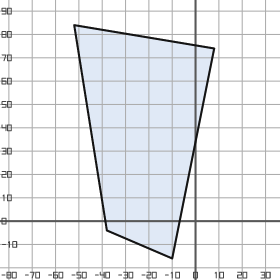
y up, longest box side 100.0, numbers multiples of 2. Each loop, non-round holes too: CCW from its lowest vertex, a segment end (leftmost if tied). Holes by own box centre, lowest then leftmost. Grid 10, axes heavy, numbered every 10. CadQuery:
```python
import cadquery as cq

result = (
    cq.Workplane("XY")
    .moveTo(-10.0, -16.0)
    .lineTo(8.0, 74.0)
    .lineTo(-52.0, 84.0)
    .lineTo(-38.0, -4.0)
    .close()
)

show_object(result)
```